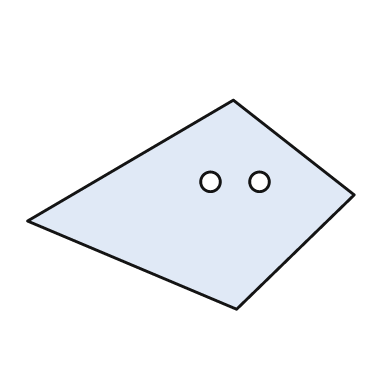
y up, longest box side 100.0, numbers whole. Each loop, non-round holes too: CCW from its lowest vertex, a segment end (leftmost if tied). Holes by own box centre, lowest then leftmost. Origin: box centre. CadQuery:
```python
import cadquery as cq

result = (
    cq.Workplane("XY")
    .moveTo(14.0, -32.0)
    .lineTo(50.0, 3.0)
    .lineTo(13.0, 32.0)
    .lineTo(-50.0, -5.0)
    .close()
    .moveTo(6.0, 7.0)
    .circle(3.0)
    .moveTo(21.0, 7.0)
    .circle(3.0)
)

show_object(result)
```